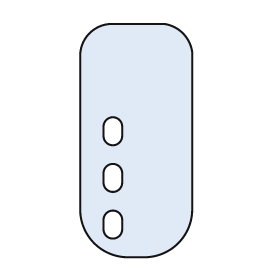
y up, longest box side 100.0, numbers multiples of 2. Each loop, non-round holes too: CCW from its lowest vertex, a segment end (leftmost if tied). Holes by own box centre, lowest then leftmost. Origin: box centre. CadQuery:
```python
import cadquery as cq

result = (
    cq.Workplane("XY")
    .moveTo(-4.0, -50.0)
    .lineTo(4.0, -50.0)
    .threePointArc((18.0, -44.0), (24.0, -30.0))
    .lineTo(24.0, 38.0)
    .threePointArc((20.0, 46.0), (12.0, 50.0))
    .lineTo(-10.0, 50.0)
    .threePointArc((-20.0, 46.0), (-24.0, 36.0))
    .lineTo(-24.0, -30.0)
    .threePointArc((-18.0, -44.0), (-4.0, -50.0))
    .close()
    .moveTo(-14.0, -38.0)
    .threePointArc((-10.0, -42.0), (-6.0, -38.0))
    .lineTo(-6.0, -34.0)
    .threePointArc((-10.0, -30.0), (-14.0, -34.0))
    .close()
    .moveTo(-14.0, -18.0)
    .threePointArc((-10.0, -22.0), (-6.0, -18.0))
    .lineTo(-6.0, -14.0)
    .threePointArc((-10.0, -10.0), (-14.0, -14.0))
    .close()
    .moveTo(-14.0, 2.0)
    .threePointArc((-10.0, -2.0), (-6.0, 2.0))
    .lineTo(-6.0, 6.0)
    .threePointArc((-10.0, 10.0), (-14.0, 6.0))
    .close()
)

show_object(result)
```